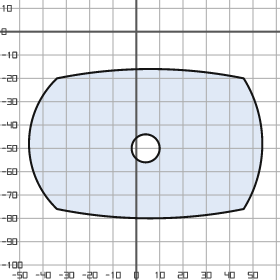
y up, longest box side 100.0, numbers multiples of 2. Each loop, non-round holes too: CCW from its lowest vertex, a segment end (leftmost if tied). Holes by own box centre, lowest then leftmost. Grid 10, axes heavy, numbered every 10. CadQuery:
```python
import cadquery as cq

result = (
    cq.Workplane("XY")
    .moveTo(-34.0, -76.0)
    .threePointArc((6.0, -80.0), (46.0, -76.0))
    .threePointArc((54.0, -48.0), (46.0, -20.0))
    .threePointArc((6.0, -16.0), (-34.0, -20.0))
    .threePointArc((-46.0, -48.0), (-34.0, -76.0))
    .close()
    .moveTo(4.0, -50.0)
    .circle(6.0)
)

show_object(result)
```